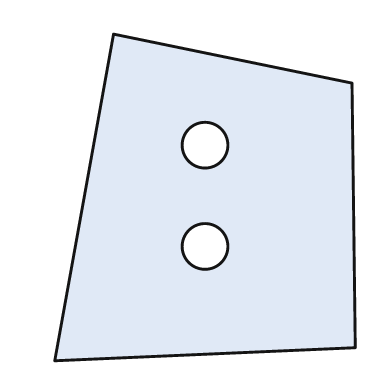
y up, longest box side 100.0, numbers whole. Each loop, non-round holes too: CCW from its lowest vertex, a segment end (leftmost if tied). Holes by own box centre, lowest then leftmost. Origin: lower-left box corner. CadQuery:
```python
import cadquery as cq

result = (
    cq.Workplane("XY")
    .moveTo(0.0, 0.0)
    .lineTo(92.0, 4.0)
    .lineTo(91.0, 85.0)
    .lineTo(18.0, 100.0)
    .close()
    .moveTo(46.0, 35.0)
    .circle(7.0)
    .moveTo(46.0, 66.0)
    .circle(7.0)
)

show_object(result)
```